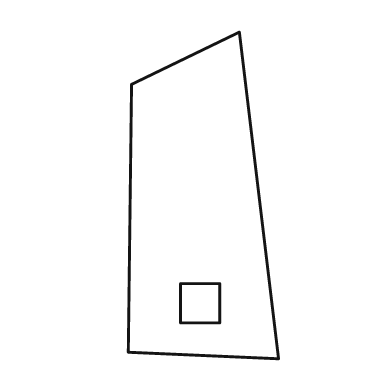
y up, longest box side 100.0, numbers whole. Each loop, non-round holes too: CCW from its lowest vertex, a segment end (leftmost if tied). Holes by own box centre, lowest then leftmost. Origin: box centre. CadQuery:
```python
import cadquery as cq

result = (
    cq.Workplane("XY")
    .moveTo(23.0, -50.0)
    .lineTo(11.0, 50.0)
    .lineTo(-22.0, 34.0)
    .lineTo(-23.0, -48.0)
    .close()
    .moveTo(-7.0, -39.0)
    .lineTo(5.0, -39.0)
    .lineTo(5.0, -27.0)
    .lineTo(-7.0, -27.0)
    .close()
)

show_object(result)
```